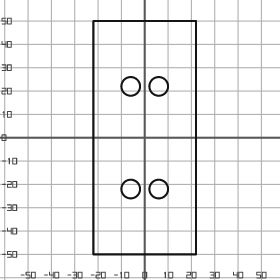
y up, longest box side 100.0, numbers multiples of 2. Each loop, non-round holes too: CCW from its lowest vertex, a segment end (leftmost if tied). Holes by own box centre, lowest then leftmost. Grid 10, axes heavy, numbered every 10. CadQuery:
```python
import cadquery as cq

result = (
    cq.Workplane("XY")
    .moveTo(-22.0, -50.0)
    .lineTo(22.0, -50.0)
    .lineTo(22.0, 50.0)
    .lineTo(-22.0, 50.0)
    .close()
    .moveTo(-6.0, -22.0)
    .circle(4.0)
    .moveTo(6.0, -22.0)
    .circle(4.0)
    .moveTo(-6.0, 22.0)
    .circle(4.0)
    .moveTo(6.0, 22.0)
    .circle(4.0)
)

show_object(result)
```